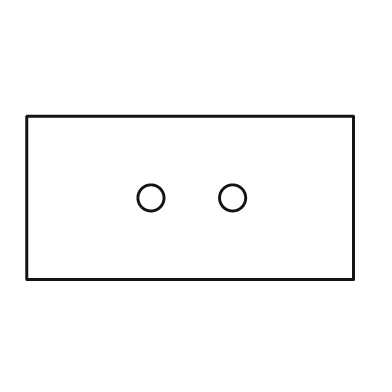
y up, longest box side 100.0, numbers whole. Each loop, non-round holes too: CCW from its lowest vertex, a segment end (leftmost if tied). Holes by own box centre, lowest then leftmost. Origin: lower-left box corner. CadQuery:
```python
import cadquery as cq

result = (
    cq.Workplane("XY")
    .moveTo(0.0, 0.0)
    .lineTo(100.0, 0.0)
    .lineTo(100.0, 50.0)
    .lineTo(0.0, 50.0)
    .close()
    .moveTo(38.0, 25.0)
    .circle(4.0)
    .moveTo(63.0, 25.0)
    .circle(4.0)
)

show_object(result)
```